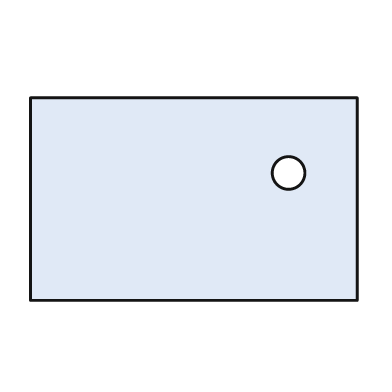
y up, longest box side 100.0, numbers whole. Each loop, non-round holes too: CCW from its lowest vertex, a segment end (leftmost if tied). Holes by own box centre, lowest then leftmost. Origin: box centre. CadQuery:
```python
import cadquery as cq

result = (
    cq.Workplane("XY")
    .moveTo(-50.0, -31.0)
    .lineTo(50.0, -31.0)
    .lineTo(50.0, 31.0)
    .lineTo(-50.0, 31.0)
    .close()
    .moveTo(29.0, 8.0)
    .circle(5.0)
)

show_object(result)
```